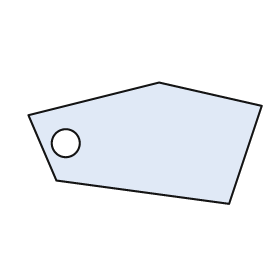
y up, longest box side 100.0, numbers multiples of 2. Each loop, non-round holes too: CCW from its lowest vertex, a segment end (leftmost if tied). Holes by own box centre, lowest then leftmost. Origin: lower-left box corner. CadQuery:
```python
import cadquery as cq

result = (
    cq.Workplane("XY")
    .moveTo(86.0, 0.0)
    .lineTo(100.0, 42.0)
    .lineTo(56.0, 52.0)
    .lineTo(0.0, 38.0)
    .lineTo(12.0, 10.0)
    .close()
    .moveTo(16.0, 26.0)
    .circle(6.0)
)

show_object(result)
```